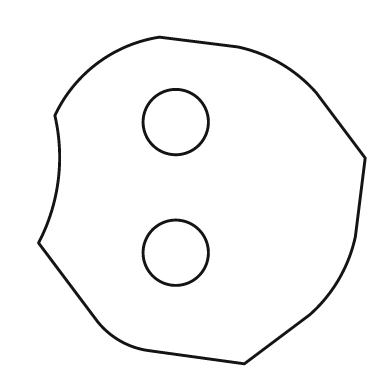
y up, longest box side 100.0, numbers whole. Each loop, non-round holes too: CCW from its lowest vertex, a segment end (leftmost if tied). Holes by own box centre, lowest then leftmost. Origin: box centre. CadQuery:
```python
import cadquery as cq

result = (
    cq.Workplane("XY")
    .moveTo(13.0, -50.0)
    .lineTo(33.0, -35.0)
    .threePointArc((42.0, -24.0), (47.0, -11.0))
    .lineTo(50.0, 13.0)
    .lineTo(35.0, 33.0)
    .threePointArc((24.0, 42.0), (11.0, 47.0))
    .lineTo(-13.0, 50.0)
    .threePointArc((-32.0, 42.0), (-45.0, 26.0))
    .threePointArc((-44.0, 6.0), (-50.0, -13.0))
    .lineTo(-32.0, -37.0)
    .threePointArc((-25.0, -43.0), (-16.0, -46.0))
    .close()
    .moveTo(-8.0, -16.0)
    .circle(10.0)
    .moveTo(-8.0, 24.0)
    .circle(10.0)
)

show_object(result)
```